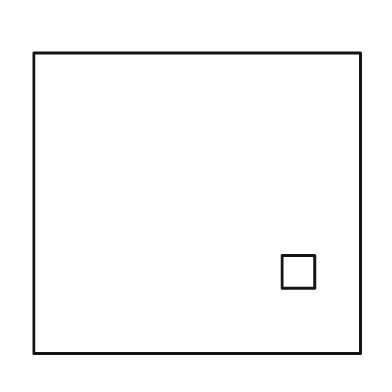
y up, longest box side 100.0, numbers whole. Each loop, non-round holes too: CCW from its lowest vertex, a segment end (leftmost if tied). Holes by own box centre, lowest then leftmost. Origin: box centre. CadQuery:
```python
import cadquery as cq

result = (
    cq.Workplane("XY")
    .moveTo(-50.0, -46.0)
    .lineTo(50.0, -46.0)
    .lineTo(50.0, 46.0)
    .lineTo(-50.0, 46.0)
    .close()
    .moveTo(26.0, -26.0)
    .lineTo(36.0, -26.0)
    .lineTo(36.0, -16.0)
    .lineTo(26.0, -16.0)
    .close()
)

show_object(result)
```